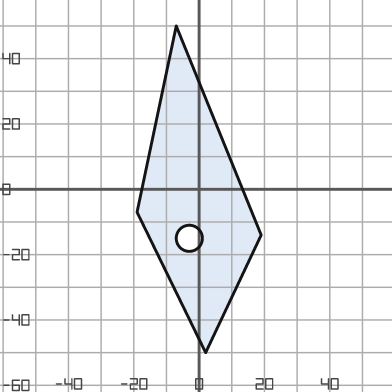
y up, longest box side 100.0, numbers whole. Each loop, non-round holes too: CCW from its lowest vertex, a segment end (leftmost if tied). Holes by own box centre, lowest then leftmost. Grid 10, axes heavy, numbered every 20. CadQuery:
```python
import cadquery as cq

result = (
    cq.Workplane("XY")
    .moveTo(2.0, -50.0)
    .lineTo(19.0, -14.0)
    .lineTo(-7.0, 50.0)
    .lineTo(-19.0, -7.0)
    .close()
    .moveTo(-3.0, -15.0)
    .circle(4.0)
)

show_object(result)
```